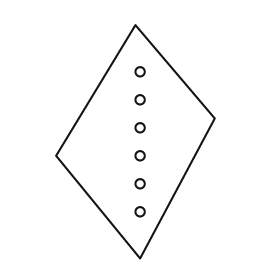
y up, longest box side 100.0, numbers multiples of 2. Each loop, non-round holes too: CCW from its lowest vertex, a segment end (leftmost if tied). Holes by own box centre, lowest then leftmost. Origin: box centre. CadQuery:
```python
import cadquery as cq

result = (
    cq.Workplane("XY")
    .moveTo(2.0, -50.0)
    .lineTo(34.0, 10.0)
    .lineTo(0.0, 50.0)
    .lineTo(-34.0, -6.0)
    .close()
    .moveTo(2.0, -30.0)
    .circle(2.0)
    .moveTo(2.0, -18.0)
    .circle(2.0)
    .moveTo(2.0, -6.0)
    .circle(2.0)
    .moveTo(2.0, 6.0)
    .circle(2.0)
    .moveTo(2.0, 18.0)
    .circle(2.0)
    .moveTo(2.0, 30.0)
    .circle(2.0)
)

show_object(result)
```